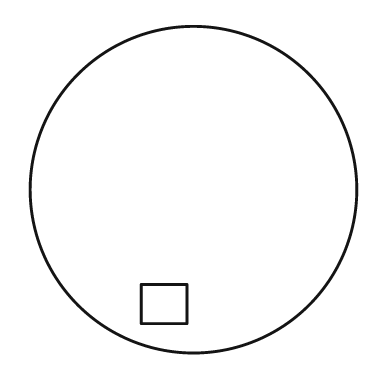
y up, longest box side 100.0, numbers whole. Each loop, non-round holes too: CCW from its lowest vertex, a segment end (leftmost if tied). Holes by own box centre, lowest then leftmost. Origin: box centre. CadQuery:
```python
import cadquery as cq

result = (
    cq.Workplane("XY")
    .moveTo(0.0, 0.0)
    .circle(50.0)
    .moveTo(-16.0, -41.0)
    .lineTo(-2.0, -41.0)
    .lineTo(-2.0, -29.0)
    .lineTo(-16.0, -29.0)
    .close()
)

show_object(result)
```